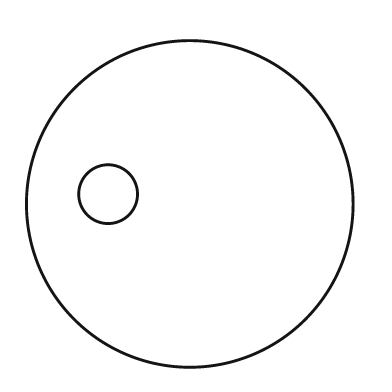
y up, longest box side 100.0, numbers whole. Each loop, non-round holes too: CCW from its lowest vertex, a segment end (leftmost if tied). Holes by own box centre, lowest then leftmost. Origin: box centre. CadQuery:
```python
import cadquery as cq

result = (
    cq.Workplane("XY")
    .moveTo(0.0, 0.0)
    .circle(50.0)
    .moveTo(-25.0, 3.0)
    .circle(9.0)
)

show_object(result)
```